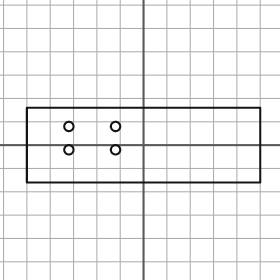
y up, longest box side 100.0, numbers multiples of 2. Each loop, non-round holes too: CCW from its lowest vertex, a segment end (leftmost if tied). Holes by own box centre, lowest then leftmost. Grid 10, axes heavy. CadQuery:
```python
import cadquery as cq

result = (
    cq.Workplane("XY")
    .moveTo(-50.0, -16.0)
    .lineTo(50.0, -16.0)
    .lineTo(50.0, 16.0)
    .lineTo(-50.0, 16.0)
    .close()
    .moveTo(-32.0, -2.0)
    .circle(2.0)
    .moveTo(-12.0, -2.0)
    .circle(2.0)
    .moveTo(-32.0, 8.0)
    .circle(2.0)
    .moveTo(-12.0, 8.0)
    .circle(2.0)
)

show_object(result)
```